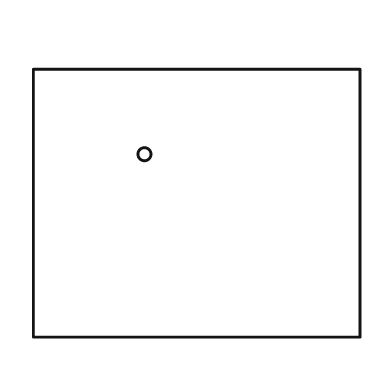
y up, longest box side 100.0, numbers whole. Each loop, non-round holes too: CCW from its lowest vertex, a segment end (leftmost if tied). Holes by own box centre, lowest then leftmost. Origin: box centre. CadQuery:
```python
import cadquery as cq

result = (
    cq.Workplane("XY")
    .moveTo(-50.0, -41.0)
    .lineTo(50.0, -41.0)
    .lineTo(50.0, 41.0)
    .lineTo(-50.0, 41.0)
    .close()
    .moveTo(-16.0, 15.0)
    .circle(2.0)
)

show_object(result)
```